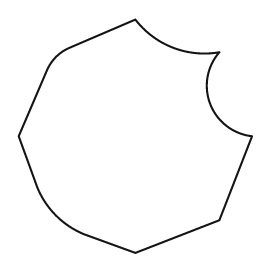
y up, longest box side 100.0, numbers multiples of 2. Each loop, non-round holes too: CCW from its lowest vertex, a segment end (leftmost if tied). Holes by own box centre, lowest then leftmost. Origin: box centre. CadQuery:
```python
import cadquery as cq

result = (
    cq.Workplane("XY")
    .moveTo(0.0, -50.0)
    .lineTo(36.0, -36.0)
    .lineTo(50.0, 0.0)
    .threePointArc((32.0, 14.0), (36.0, 36.0))
    .threePointArc((16.0, 38.0), (0.0, 50.0))
    .lineTo(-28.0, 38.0)
    .threePointArc((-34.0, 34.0), (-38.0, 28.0))
    .lineTo(-50.0, 0.0)
    .lineTo(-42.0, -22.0)
    .threePointArc((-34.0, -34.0), (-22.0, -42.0))
    .close()
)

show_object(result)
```